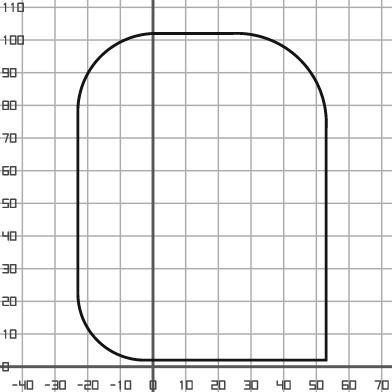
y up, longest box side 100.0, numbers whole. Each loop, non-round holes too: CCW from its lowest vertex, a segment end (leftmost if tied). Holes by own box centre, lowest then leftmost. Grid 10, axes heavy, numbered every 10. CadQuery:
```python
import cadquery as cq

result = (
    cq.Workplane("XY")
    .moveTo(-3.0, 2.0)
    .lineTo(53.0, 2.0)
    .lineTo(53.0, 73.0)
    .threePointArc((45.0, 94.0), (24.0, 102.0))
    .lineTo(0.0, 102.0)
    .threePointArc((-16.0, 95.0), (-23.0, 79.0))
    .lineTo(-23.0, 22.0)
    .threePointArc((-17.0, 8.0), (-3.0, 2.0))
    .close()
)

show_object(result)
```